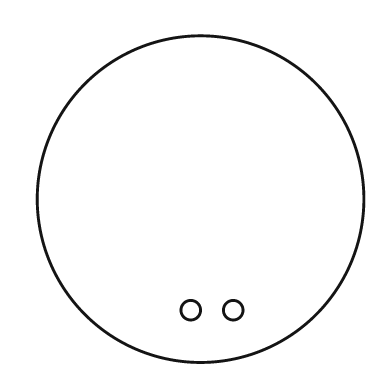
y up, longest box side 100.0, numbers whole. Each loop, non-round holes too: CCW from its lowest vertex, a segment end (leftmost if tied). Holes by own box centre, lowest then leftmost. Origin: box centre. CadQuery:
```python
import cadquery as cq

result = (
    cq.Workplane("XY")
    .moveTo(0.0, 0.0)
    .circle(50.0)
    .moveTo(-3.0, -34.0)
    .circle(3.0)
    .moveTo(10.0, -34.0)
    .circle(3.0)
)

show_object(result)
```